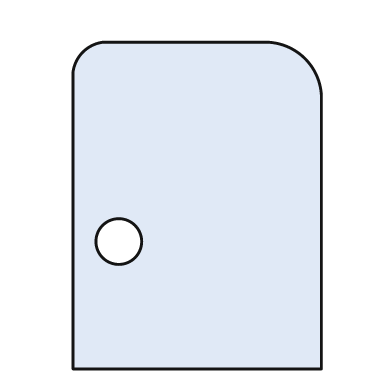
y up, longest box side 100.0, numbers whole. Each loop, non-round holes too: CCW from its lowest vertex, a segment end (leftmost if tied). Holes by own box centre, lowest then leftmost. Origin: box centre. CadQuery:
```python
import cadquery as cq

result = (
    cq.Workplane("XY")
    .moveTo(-38.0, -50.0)
    .lineTo(38.0, -50.0)
    .lineTo(38.0, 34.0)
    .threePointArc((33.0, 45.0), (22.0, 50.0))
    .lineTo(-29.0, 50.0)
    .threePointArc((-35.0, 47.0), (-38.0, 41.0))
    .close()
    .moveTo(-24.0, -11.0)
    .circle(7.0)
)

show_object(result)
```